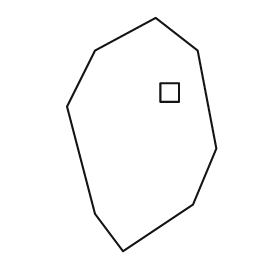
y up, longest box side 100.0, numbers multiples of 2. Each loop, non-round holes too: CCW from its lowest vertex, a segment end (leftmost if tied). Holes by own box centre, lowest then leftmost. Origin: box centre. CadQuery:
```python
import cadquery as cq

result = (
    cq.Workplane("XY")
    .moveTo(-8.0, -50.0)
    .lineTo(22.0, -30.0)
    .lineTo(32.0, -6.0)
    .lineTo(24.0, 36.0)
    .lineTo(6.0, 50.0)
    .lineTo(-20.0, 36.0)
    .lineTo(-32.0, 12.0)
    .lineTo(-20.0, -34.0)
    .close()
    .moveTo(8.0, 14.0)
    .lineTo(16.0, 14.0)
    .lineTo(16.0, 22.0)
    .lineTo(8.0, 22.0)
    .close()
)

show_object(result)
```